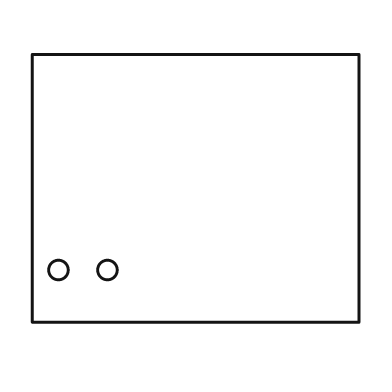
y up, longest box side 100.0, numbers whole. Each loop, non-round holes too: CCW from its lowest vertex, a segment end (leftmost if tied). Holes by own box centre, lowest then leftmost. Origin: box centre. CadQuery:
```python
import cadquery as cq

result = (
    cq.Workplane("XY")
    .moveTo(-50.0, -41.0)
    .lineTo(50.0, -41.0)
    .lineTo(50.0, 41.0)
    .lineTo(-50.0, 41.0)
    .close()
    .moveTo(-42.0, -25.0)
    .circle(3.0)
    .moveTo(-27.0, -25.0)
    .circle(3.0)
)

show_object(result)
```